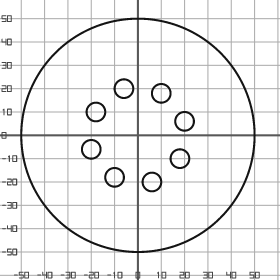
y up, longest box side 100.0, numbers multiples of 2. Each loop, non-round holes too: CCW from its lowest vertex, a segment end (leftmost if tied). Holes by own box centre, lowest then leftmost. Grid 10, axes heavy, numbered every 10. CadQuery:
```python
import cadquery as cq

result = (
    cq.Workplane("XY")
    .moveTo(0.0, 0.0)
    .circle(50.0)
    .moveTo(6.0, -20.0)
    .circle(4.0)
    .moveTo(-10.0, -18.0)
    .circle(4.0)
    .moveTo(18.0, -10.0)
    .circle(4.0)
    .moveTo(-20.0, -6.0)
    .circle(4.0)
    .moveTo(20.0, 6.0)
    .circle(4.0)
    .moveTo(-18.0, 10.0)
    .circle(4.0)
    .moveTo(10.0, 18.0)
    .circle(4.0)
    .moveTo(-6.0, 20.0)
    .circle(4.0)
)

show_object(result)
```